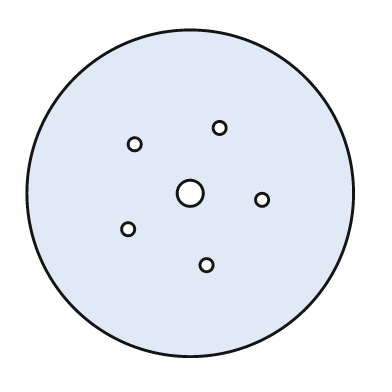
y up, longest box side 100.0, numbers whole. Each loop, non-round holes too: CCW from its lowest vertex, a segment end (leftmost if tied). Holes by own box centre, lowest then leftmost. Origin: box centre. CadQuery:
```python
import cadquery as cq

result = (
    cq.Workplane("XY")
    .moveTo(0.0, 0.0)
    .circle(50.0)
    .moveTo(5.0, -22.0)
    .circle(2.0)
    .moveTo(-19.0, -11.0)
    .circle(2.0)
    .moveTo(22.0, -2.0)
    .circle(2.0)
    .moveTo(0.0, 0.0)
    .circle(4.0)
    .moveTo(-17.0, 15.0)
    .circle(2.0)
    .moveTo(9.0, 20.0)
    .circle(2.0)
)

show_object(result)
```